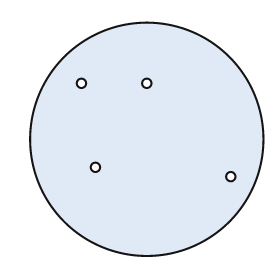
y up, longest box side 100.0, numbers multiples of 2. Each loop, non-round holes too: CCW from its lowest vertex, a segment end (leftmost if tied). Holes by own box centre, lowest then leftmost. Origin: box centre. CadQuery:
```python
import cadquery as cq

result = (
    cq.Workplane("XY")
    .moveTo(0.0, 0.0)
    .circle(50.0)
    .moveTo(36.0, -16.0)
    .circle(2.0)
    .moveTo(-22.0, -12.0)
    .circle(2.0)
    .moveTo(-28.0, 24.0)
    .circle(2.0)
    .moveTo(0.0, 24.0)
    .circle(2.0)
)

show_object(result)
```